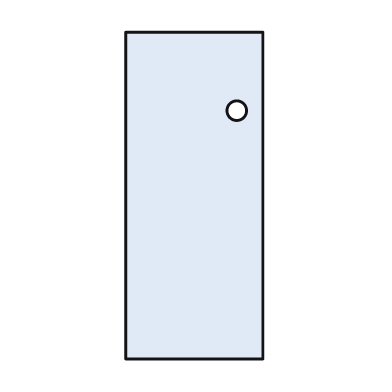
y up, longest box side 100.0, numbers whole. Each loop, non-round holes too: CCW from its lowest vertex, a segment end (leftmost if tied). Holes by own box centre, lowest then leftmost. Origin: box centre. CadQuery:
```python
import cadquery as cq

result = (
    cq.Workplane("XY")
    .moveTo(-21.0, -50.0)
    .lineTo(21.0, -50.0)
    .lineTo(21.0, 50.0)
    .lineTo(-21.0, 50.0)
    .close()
    .moveTo(13.0, 26.0)
    .circle(3.0)
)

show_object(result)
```